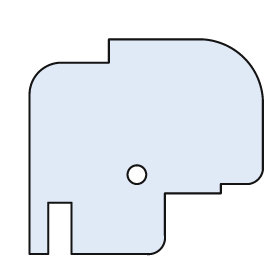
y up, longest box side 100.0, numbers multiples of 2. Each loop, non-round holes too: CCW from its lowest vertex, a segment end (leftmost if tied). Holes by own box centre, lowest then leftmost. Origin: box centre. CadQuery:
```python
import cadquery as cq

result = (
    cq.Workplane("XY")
    .moveTo(-50.0, -46.0)
    .lineTo(-42.0, -46.0)
    .lineTo(-42.0, -24.0)
    .lineTo(-32.0, -24.0)
    .lineTo(-32.0, -46.0)
    .lineTo(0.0, -46.0)
    .threePointArc((6.0, -44.0), (8.0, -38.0))
    .lineTo(8.0, -20.0)
    .lineTo(32.0, -20.0)
    .lineTo(32.0, -16.0)
    .lineTo(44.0, -16.0)
    .threePointArc((48.0, -14.0), (50.0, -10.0))
    .lineTo(50.0, 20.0)
    .threePointArc((42.0, 38.0), (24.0, 46.0))
    .lineTo(-16.0, 46.0)
    .lineTo(-16.0, 36.0)
    .lineTo(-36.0, 36.0)
    .threePointArc((-46.0, 32.0), (-50.0, 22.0))
    .close()
    .moveTo(-4.0, -12.0)
    .circle(4.0)
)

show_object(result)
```